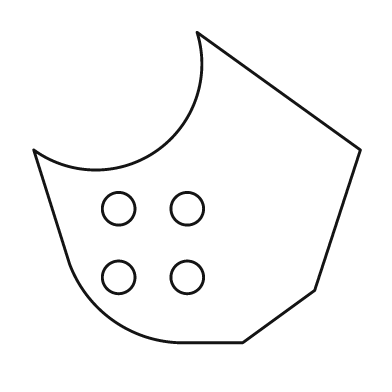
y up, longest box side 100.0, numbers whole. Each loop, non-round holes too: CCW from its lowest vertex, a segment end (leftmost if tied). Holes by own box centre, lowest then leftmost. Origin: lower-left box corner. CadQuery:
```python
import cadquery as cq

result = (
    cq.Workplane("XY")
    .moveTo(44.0, 0.0)
    .lineTo(64.0, 0.0)
    .lineTo(86.0, 16.0)
    .lineTo(100.0, 59.0)
    .lineTo(50.0, 95.0)
    .threePointArc((38.0, 59.0), (0.0, 59.0))
    .lineTo(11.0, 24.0)
    .threePointArc((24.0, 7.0), (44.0, 0.0))
    .close()
    .moveTo(26.0, 20.0)
    .circle(5.0)
    .moveTo(47.0, 20.0)
    .circle(5.0)
    .moveTo(26.0, 41.0)
    .circle(5.0)
    .moveTo(47.0, 41.0)
    .circle(5.0)
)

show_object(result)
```